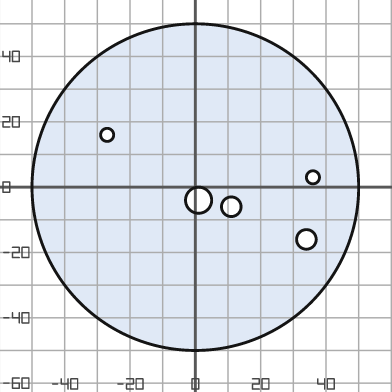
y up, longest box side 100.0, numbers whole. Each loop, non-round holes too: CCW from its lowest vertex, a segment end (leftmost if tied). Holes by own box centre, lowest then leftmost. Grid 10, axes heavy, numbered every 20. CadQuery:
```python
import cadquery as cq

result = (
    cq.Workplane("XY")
    .moveTo(0.0, 0.0)
    .circle(50.0)
    .moveTo(34.0, -16.0)
    .circle(3.0)
    .moveTo(11.0, -6.0)
    .circle(3.0)
    .moveTo(1.0, -4.0)
    .circle(4.0)
    .moveTo(36.0, 3.0)
    .circle(2.0)
    .moveTo(-27.0, 16.0)
    .circle(2.0)
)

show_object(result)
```